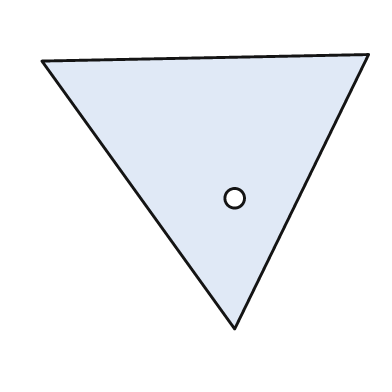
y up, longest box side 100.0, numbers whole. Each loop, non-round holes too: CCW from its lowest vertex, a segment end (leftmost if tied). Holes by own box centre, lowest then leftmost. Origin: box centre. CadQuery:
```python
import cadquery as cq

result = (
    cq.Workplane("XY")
    .moveTo(9.0, -42.0)
    .lineTo(50.0, 42.0)
    .lineTo(-50.0, 40.0)
    .close()
    .moveTo(9.0, -2.0)
    .circle(3.0)
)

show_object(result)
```